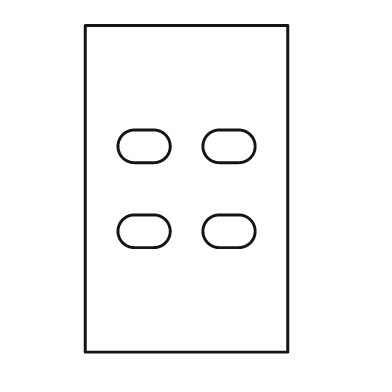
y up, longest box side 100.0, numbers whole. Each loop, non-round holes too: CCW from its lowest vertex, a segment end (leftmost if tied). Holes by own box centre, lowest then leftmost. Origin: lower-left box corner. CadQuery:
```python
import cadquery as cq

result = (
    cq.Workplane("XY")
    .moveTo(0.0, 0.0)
    .lineTo(62.0, 0.0)
    .lineTo(62.0, 100.0)
    .lineTo(0.0, 100.0)
    .close()
    .moveTo(15.0, 32.0)
    .lineTo(21.0, 32.0)
    .threePointArc((26.0, 37.0), (21.0, 42.0))
    .lineTo(15.0, 42.0)
    .threePointArc((10.0, 37.0), (15.0, 32.0))
    .close()
    .moveTo(41.0, 32.0)
    .lineTo(47.0, 32.0)
    .threePointArc((52.0, 37.0), (47.0, 42.0))
    .lineTo(41.0, 42.0)
    .threePointArc((36.0, 37.0), (41.0, 32.0))
    .close()
    .moveTo(15.0, 58.0)
    .lineTo(21.0, 58.0)
    .threePointArc((26.0, 63.0), (21.0, 68.0))
    .lineTo(15.0, 68.0)
    .threePointArc((10.0, 63.0), (15.0, 58.0))
    .close()
    .moveTo(41.0, 58.0)
    .lineTo(47.0, 58.0)
    .threePointArc((52.0, 63.0), (47.0, 68.0))
    .lineTo(41.0, 68.0)
    .threePointArc((36.0, 63.0), (41.0, 58.0))
    .close()
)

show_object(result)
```